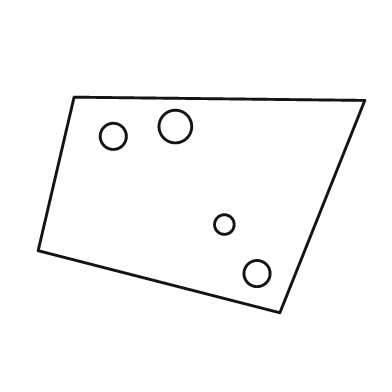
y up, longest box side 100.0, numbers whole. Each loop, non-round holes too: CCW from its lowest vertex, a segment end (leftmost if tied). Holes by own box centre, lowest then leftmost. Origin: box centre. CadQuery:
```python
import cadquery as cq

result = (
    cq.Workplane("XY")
    .moveTo(24.0, -33.0)
    .lineTo(50.0, 32.0)
    .lineTo(-39.0, 33.0)
    .lineTo(-50.0, -14.0)
    .close()
    .moveTo(17.0, -21.0)
    .circle(4.0)
    .moveTo(7.0, -6.0)
    .circle(3.0)
    .moveTo(-27.0, 21.0)
    .circle(4.0)
    .moveTo(-8.0, 24.0)
    .circle(5.0)
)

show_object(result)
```